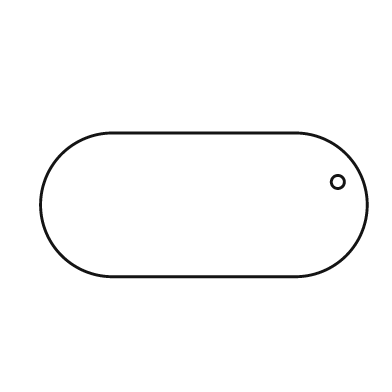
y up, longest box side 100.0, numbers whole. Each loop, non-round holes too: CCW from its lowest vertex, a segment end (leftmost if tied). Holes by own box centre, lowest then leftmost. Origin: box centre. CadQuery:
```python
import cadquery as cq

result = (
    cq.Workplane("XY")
    .moveTo(-28.0, -22.0)
    .lineTo(28.0, -22.0)
    .threePointArc((50.0, 0.0), (28.0, 22.0))
    .lineTo(-28.0, 22.0)
    .threePointArc((-50.0, 0.0), (-28.0, -22.0))
    .close()
    .moveTo(41.0, 7.0)
    .circle(2.0)
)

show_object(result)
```